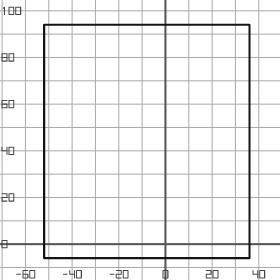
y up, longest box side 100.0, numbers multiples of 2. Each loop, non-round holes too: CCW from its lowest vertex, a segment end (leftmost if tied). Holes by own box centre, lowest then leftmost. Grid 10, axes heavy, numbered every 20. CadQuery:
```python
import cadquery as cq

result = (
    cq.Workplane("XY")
    .moveTo(-52.0, -6.0)
    .lineTo(36.0, -6.0)
    .lineTo(36.0, 94.0)
    .lineTo(-52.0, 94.0)
    .close()
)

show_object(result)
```